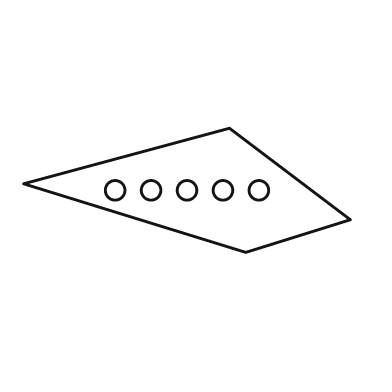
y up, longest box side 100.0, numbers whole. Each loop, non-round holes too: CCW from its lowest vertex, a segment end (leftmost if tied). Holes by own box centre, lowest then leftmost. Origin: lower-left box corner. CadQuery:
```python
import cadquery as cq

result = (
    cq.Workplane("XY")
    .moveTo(68.0, 0.0)
    .lineTo(100.0, 10.0)
    .lineTo(63.0, 38.0)
    .lineTo(0.0, 21.0)
    .close()
    .moveTo(28.0, 19.0)
    .circle(3.0)
    .moveTo(39.0, 19.0)
    .circle(3.0)
    .moveTo(50.0, 19.0)
    .circle(3.0)
    .moveTo(61.0, 19.0)
    .circle(3.0)
    .moveTo(72.0, 19.0)
    .circle(3.0)
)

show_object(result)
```